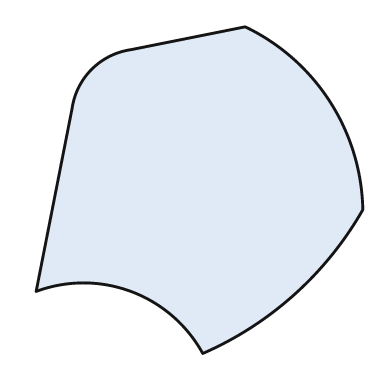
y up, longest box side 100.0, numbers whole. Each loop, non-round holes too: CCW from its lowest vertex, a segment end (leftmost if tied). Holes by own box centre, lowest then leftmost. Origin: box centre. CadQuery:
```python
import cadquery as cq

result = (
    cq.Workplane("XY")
    .moveTo(1.0, -50.0)
    .threePointArc((29.0, -32.0), (50.0, -6.0))
    .threePointArc((40.0, 27.0), (14.0, 50.0))
    .lineTo(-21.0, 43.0)
    .threePointArc((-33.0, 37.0), (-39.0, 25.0))
    .lineTo(-50.0, -31.0)
    .threePointArc((-21.0, -31.0), (1.0, -50.0))
    .close()
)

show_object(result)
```